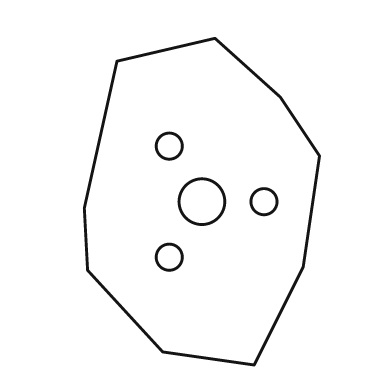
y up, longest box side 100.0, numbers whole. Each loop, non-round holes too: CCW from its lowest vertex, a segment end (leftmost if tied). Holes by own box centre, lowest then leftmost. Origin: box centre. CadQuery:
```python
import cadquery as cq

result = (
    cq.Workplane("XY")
    .moveTo(16.0, -50.0)
    .lineTo(31.0, -20.0)
    .lineTo(36.0, 14.0)
    .lineTo(24.0, 32.0)
    .lineTo(4.0, 50.0)
    .lineTo(-26.0, 43.0)
    .lineTo(-36.0, -2.0)
    .lineTo(-35.0, -21.0)
    .lineTo(-12.0, -46.0)
    .close()
    .moveTo(-10.0, -17.0)
    .circle(4.0)
    .moveTo(0.0, 0.0)
    .circle(7.0)
    .moveTo(19.0, 0.0)
    .circle(4.0)
    .moveTo(-10.0, 17.0)
    .circle(4.0)
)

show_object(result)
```